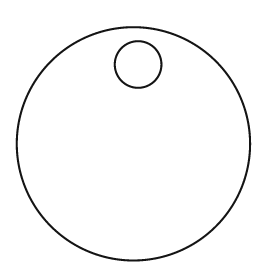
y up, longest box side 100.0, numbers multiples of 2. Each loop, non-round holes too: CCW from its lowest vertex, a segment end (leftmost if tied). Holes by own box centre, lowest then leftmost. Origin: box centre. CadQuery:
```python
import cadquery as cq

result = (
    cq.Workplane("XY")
    .moveTo(0.0, 0.0)
    .circle(50.0)
    .moveTo(2.0, 34.0)
    .circle(10.0)
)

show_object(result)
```